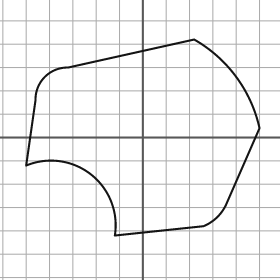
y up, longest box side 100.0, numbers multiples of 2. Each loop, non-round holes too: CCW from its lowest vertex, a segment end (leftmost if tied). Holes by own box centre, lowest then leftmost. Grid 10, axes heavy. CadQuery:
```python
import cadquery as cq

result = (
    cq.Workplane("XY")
    .moveTo(-12.0, -42.0)
    .lineTo(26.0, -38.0)
    .threePointArc((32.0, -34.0), (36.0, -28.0))
    .lineTo(50.0, 4.0)
    .threePointArc((40.0, 26.0), (22.0, 42.0))
    .lineTo(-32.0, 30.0)
    .threePointArc((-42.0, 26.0), (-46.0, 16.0))
    .lineTo(-50.0, -12.0)
    .threePointArc((-22.0, -16.0), (-12.0, -42.0))
    .close()
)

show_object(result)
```